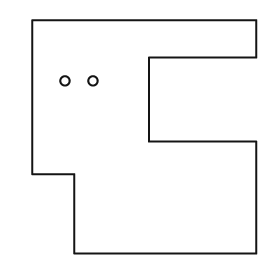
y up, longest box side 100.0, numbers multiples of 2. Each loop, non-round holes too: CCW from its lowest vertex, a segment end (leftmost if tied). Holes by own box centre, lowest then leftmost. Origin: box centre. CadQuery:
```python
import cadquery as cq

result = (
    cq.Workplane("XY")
    .moveTo(-30.0, -50.0)
    .lineTo(48.0, -50.0)
    .lineTo(48.0, -2.0)
    .lineTo(2.0, -2.0)
    .lineTo(2.0, 34.0)
    .lineTo(48.0, 34.0)
    .lineTo(48.0, 50.0)
    .lineTo(-48.0, 50.0)
    .lineTo(-48.0, -16.0)
    .lineTo(-30.0, -16.0)
    .close()
    .moveTo(-34.0, 24.0)
    .circle(2.0)
    .moveTo(-22.0, 24.0)
    .circle(2.0)
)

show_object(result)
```